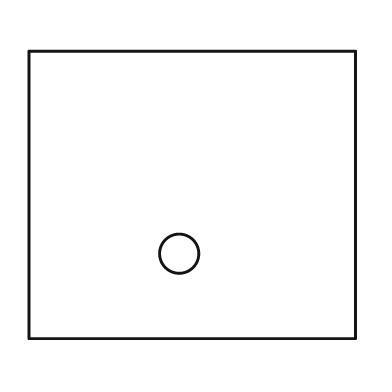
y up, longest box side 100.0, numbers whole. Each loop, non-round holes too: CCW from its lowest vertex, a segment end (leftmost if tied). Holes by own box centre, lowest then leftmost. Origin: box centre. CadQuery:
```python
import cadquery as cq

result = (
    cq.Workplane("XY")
    .moveTo(-50.0, -44.0)
    .lineTo(50.0, -44.0)
    .lineTo(50.0, 44.0)
    .lineTo(-50.0, 44.0)
    .close()
    .moveTo(-4.0, -18.0)
    .circle(6.0)
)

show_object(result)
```